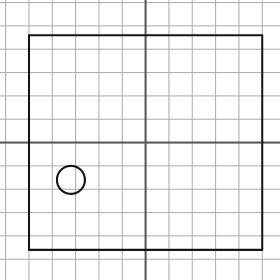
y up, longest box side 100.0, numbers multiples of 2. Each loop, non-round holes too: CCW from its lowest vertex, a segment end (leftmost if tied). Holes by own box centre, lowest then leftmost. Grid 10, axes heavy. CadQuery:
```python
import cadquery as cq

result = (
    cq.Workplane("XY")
    .moveTo(-50.0, -46.0)
    .lineTo(50.0, -46.0)
    .lineTo(50.0, 46.0)
    .lineTo(-50.0, 46.0)
    .close()
    .moveTo(-32.0, -16.0)
    .circle(6.0)
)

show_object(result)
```